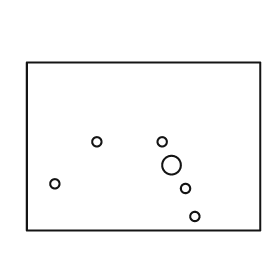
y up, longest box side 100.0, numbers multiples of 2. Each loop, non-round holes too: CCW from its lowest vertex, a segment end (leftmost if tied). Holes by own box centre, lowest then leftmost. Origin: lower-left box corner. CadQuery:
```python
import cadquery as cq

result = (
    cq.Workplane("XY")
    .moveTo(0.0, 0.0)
    .lineTo(100.0, 0.0)
    .lineTo(100.0, 72.0)
    .lineTo(0.0, 72.0)
    .close()
    .moveTo(72.0, 6.0)
    .circle(2.0)
    .moveTo(68.0, 18.0)
    .circle(2.0)
    .moveTo(12.0, 20.0)
    .circle(2.0)
    .moveTo(62.0, 28.0)
    .circle(4.0)
    .moveTo(30.0, 38.0)
    .circle(2.0)
    .moveTo(58.0, 38.0)
    .circle(2.0)
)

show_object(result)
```